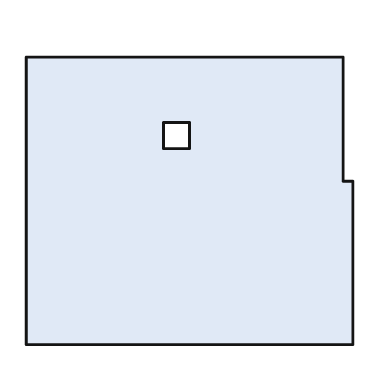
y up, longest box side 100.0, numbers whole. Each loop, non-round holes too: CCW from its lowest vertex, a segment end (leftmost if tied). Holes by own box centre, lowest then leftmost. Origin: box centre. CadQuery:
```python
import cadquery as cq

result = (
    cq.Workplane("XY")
    .moveTo(-50.0, -44.0)
    .lineTo(50.0, -44.0)
    .lineTo(50.0, 6.0)
    .lineTo(47.0, 6.0)
    .lineTo(47.0, 44.0)
    .lineTo(-50.0, 44.0)
    .close()
    .moveTo(-8.0, 16.0)
    .lineTo(0.0, 16.0)
    .lineTo(0.0, 24.0)
    .lineTo(-8.0, 24.0)
    .close()
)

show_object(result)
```